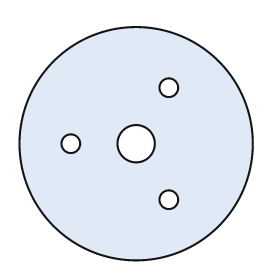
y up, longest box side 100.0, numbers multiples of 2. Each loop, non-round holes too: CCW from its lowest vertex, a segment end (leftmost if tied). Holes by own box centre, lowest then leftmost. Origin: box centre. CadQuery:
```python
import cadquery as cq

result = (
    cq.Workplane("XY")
    .moveTo(0.0, 0.0)
    .circle(50.0)
    .moveTo(14.0, -24.0)
    .circle(4.0)
    .moveTo(-28.0, 0.0)
    .circle(4.0)
    .moveTo(0.0, 0.0)
    .circle(8.0)
    .moveTo(14.0, 24.0)
    .circle(4.0)
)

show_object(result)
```